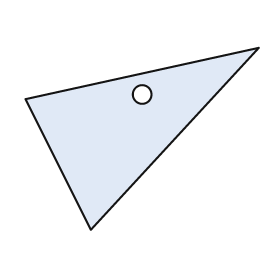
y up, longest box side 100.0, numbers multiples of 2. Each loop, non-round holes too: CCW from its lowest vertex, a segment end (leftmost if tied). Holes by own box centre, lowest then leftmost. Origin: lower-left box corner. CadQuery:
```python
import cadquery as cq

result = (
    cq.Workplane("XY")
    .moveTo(28.0, 0.0)
    .lineTo(100.0, 78.0)
    .lineTo(0.0, 56.0)
    .close()
    .moveTo(50.0, 58.0)
    .circle(4.0)
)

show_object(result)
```